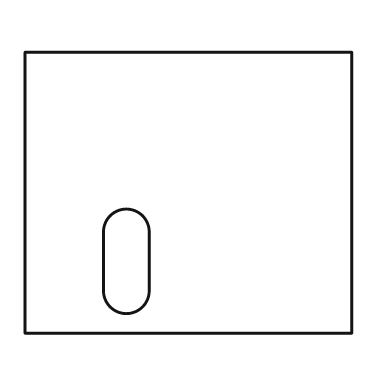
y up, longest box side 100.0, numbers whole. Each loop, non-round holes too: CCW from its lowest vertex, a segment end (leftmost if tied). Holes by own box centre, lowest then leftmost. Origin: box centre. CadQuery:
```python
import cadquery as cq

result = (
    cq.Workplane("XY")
    .moveTo(-50.0, -43.0)
    .lineTo(50.0, -43.0)
    .lineTo(50.0, 43.0)
    .lineTo(-50.0, 43.0)
    .close()
    .moveTo(-26.0, -30.0)
    .threePointArc((-19.0, -37.0), (-12.0, -30.0))
    .lineTo(-12.0, -12.0)
    .threePointArc((-19.0, -5.0), (-26.0, -12.0))
    .close()
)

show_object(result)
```